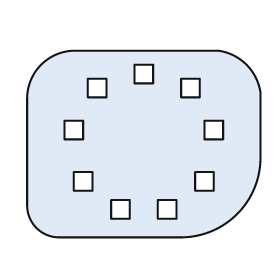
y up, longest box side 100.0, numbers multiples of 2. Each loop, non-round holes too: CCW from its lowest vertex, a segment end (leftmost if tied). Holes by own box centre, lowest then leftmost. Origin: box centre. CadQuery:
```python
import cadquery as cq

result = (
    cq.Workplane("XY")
    .moveTo(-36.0, -40.0)
    .lineTo(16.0, -40.0)
    .threePointArc((40.0, -30.0), (50.0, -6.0))
    .lineTo(50.0, 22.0)
    .threePointArc((44.0, 34.0), (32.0, 40.0))
    .lineTo(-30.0, 40.0)
    .threePointArc((-44.0, 34.0), (-50.0, 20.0))
    .lineTo(-50.0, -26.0)
    .threePointArc((-46.0, -36.0), (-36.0, -40.0))
    .close()
    .moveTo(-14.0, -32.0)
    .lineTo(-6.0, -32.0)
    .lineTo(-6.0, -24.0)
    .lineTo(-14.0, -24.0)
    .close()
    .moveTo(6.0, -32.0)
    .lineTo(14.0, -32.0)
    .lineTo(14.0, -24.0)
    .lineTo(6.0, -24.0)
    .close()
    .moveTo(-30.0, -20.0)
    .lineTo(-22.0, -20.0)
    .lineTo(-22.0, -12.0)
    .lineTo(-30.0, -12.0)
    .close()
    .moveTo(22.0, -20.0)
    .lineTo(30.0, -20.0)
    .lineTo(30.0, -12.0)
    .lineTo(22.0, -12.0)
    .close()
    .moveTo(-34.0, 2.0)
    .lineTo(-26.0, 2.0)
    .lineTo(-26.0, 10.0)
    .lineTo(-34.0, 10.0)
    .close()
    .moveTo(26.0, 2.0)
    .lineTo(34.0, 2.0)
    .lineTo(34.0, 10.0)
    .lineTo(26.0, 10.0)
    .close()
    .moveTo(-24.0, 20.0)
    .lineTo(-16.0, 20.0)
    .lineTo(-16.0, 28.0)
    .lineTo(-24.0, 28.0)
    .close()
    .moveTo(16.0, 20.0)
    .lineTo(24.0, 20.0)
    .lineTo(24.0, 28.0)
    .lineTo(16.0, 28.0)
    .close()
    .moveTo(-4.0, 26.0)
    .lineTo(4.0, 26.0)
    .lineTo(4.0, 34.0)
    .lineTo(-4.0, 34.0)
    .close()
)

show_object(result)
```